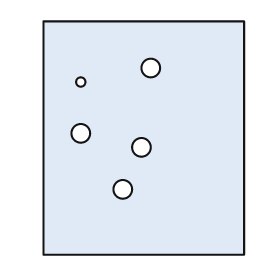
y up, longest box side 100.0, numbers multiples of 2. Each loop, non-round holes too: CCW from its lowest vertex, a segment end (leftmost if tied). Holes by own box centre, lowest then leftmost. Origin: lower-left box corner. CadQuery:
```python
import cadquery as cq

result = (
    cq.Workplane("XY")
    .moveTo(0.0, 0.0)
    .lineTo(86.0, 0.0)
    .lineTo(86.0, 100.0)
    .lineTo(0.0, 100.0)
    .close()
    .moveTo(34.0, 28.0)
    .circle(4.0)
    .moveTo(42.0, 46.0)
    .circle(4.0)
    .moveTo(16.0, 52.0)
    .circle(4.0)
    .moveTo(16.0, 74.0)
    .circle(2.0)
    .moveTo(46.0, 80.0)
    .circle(4.0)
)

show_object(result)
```